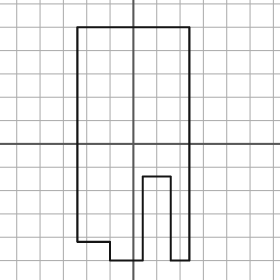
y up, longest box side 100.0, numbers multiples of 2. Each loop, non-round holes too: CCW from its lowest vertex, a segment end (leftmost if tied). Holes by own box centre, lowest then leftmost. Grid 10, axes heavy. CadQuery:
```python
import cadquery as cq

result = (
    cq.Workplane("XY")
    .moveTo(-10.0, -50.0)
    .lineTo(4.0, -50.0)
    .lineTo(4.0, -14.0)
    .lineTo(16.0, -14.0)
    .lineTo(16.0, -50.0)
    .lineTo(24.0, -50.0)
    .lineTo(24.0, 50.0)
    .lineTo(-24.0, 50.0)
    .lineTo(-24.0, -42.0)
    .lineTo(-10.0, -42.0)
    .close()
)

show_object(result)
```